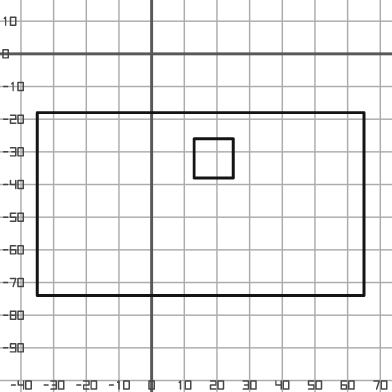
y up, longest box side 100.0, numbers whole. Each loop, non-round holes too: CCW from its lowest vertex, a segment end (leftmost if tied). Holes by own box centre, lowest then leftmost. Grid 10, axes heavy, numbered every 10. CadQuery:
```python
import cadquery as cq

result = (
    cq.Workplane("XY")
    .moveTo(-35.0, -74.0)
    .lineTo(65.0, -74.0)
    .lineTo(65.0, -18.0)
    .lineTo(-35.0, -18.0)
    .close()
    .moveTo(13.0, -38.0)
    .lineTo(25.0, -38.0)
    .lineTo(25.0, -26.0)
    .lineTo(13.0, -26.0)
    .close()
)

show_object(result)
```